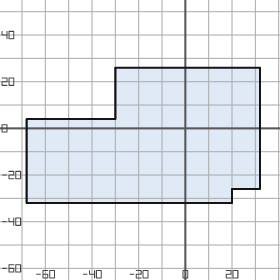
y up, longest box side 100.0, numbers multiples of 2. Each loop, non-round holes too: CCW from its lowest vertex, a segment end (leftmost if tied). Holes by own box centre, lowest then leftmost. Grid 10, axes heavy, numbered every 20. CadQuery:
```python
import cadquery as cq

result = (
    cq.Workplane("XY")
    .moveTo(-68.0, -32.0)
    .lineTo(20.0, -32.0)
    .lineTo(20.0, -26.0)
    .lineTo(32.0, -26.0)
    .lineTo(32.0, 26.0)
    .lineTo(-30.0, 26.0)
    .lineTo(-30.0, 4.0)
    .lineTo(-68.0, 4.0)
    .close()
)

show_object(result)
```